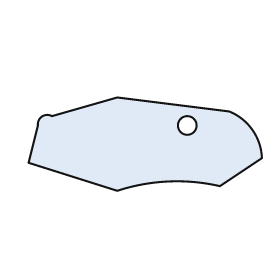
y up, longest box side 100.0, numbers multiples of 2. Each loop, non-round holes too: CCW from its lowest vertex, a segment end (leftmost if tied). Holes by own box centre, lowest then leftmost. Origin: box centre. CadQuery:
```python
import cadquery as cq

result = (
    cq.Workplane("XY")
    .moveTo(-12.0, -20.0)
    .threePointArc((10.0, -16.0), (32.0, -18.0))
    .lineTo(50.0, -6.0)
    .threePointArc((46.0, 6.0), (36.0, 14.0))
    .lineTo(-12.0, 20.0)
    .lineTo(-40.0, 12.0)
    .threePointArc((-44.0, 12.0), (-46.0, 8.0))
    .lineTo(-50.0, -8.0)
    .close()
    .moveTo(18.0, 8.0)
    .circle(4.0)
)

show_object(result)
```